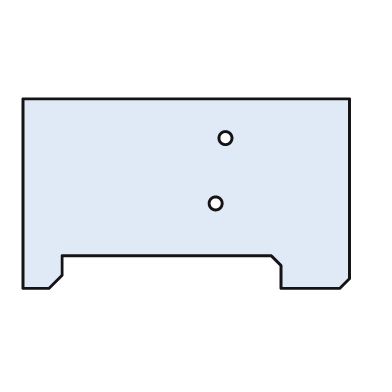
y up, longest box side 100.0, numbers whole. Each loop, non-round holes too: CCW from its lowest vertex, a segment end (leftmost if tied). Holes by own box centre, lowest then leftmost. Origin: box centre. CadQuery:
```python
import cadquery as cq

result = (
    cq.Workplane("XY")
    .moveTo(-50.0, -29.0)
    .lineTo(-42.0, -29.0)
    .lineTo(-38.0, -25.0)
    .lineTo(-38.0, -19.0)
    .lineTo(26.0, -19.0)
    .lineTo(29.0, -22.0)
    .lineTo(29.0, -29.0)
    .lineTo(47.0, -29.0)
    .lineTo(50.0, -26.0)
    .lineTo(50.0, 29.0)
    .lineTo(-50.0, 29.0)
    .close()
    .moveTo(9.0, -3.0)
    .circle(2.0)
    .moveTo(12.0, 17.0)
    .circle(2.0)
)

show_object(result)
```